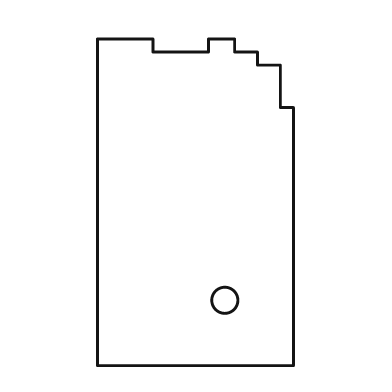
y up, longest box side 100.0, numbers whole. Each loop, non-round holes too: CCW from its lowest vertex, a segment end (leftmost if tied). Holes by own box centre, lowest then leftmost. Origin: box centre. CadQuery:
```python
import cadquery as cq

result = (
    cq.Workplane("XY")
    .moveTo(-30.0, -50.0)
    .lineTo(30.0, -50.0)
    .lineTo(30.0, 29.0)
    .lineTo(26.0, 29.0)
    .lineTo(26.0, 42.0)
    .lineTo(19.0, 42.0)
    .lineTo(19.0, 46.0)
    .lineTo(12.0, 46.0)
    .lineTo(12.0, 50.0)
    .lineTo(4.0, 50.0)
    .lineTo(4.0, 46.0)
    .lineTo(-13.0, 46.0)
    .lineTo(-13.0, 50.0)
    .lineTo(-30.0, 50.0)
    .close()
    .moveTo(9.0, -30.0)
    .circle(4.0)
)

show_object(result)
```